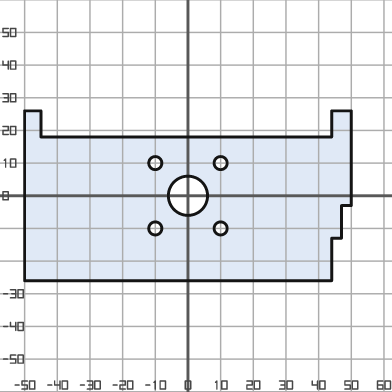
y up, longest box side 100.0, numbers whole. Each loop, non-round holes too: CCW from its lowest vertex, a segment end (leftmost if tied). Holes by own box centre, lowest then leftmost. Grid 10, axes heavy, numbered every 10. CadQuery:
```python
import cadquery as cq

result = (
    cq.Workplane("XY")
    .moveTo(-50.0, -26.0)
    .lineTo(44.0, -26.0)
    .lineTo(44.0, -13.0)
    .lineTo(47.0, -13.0)
    .lineTo(47.0, -3.0)
    .lineTo(50.0, -3.0)
    .lineTo(50.0, 26.0)
    .lineTo(44.0, 26.0)
    .lineTo(44.0, 18.0)
    .lineTo(-45.0, 18.0)
    .lineTo(-45.0, 26.0)
    .lineTo(-50.0, 26.0)
    .close()
    .moveTo(-10.0, -10.0)
    .circle(2.0)
    .moveTo(10.0, -10.0)
    .circle(2.0)
    .moveTo(0.0, 0.0)
    .circle(6.0)
    .moveTo(-10.0, 10.0)
    .circle(2.0)
    .moveTo(10.0, 10.0)
    .circle(2.0)
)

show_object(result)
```